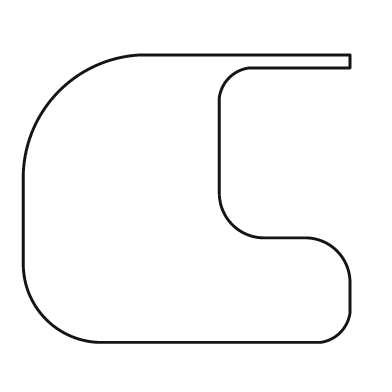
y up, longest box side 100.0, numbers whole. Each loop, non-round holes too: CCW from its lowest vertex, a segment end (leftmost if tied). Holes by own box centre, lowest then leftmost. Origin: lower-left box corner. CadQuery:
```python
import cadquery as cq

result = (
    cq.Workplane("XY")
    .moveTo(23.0, 0.0)
    .lineTo(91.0, 0.0)
    .threePointArc((97.0, 3.0), (100.0, 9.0))
    .lineTo(100.0, 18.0)
    .threePointArc((96.0, 28.0), (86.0, 32.0))
    .lineTo(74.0, 32.0)
    .threePointArc((64.0, 36.0), (60.0, 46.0))
    .lineTo(60.0, 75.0)
    .threePointArc((63.0, 81.0), (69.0, 84.0))
    .lineTo(100.0, 84.0)
    .lineTo(100.0, 88.0)
    .lineTo(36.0, 88.0)
    .threePointArc((11.0, 77.0), (0.0, 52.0))
    .lineTo(0.0, 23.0)
    .threePointArc((7.0, 7.0), (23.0, 0.0))
    .close()
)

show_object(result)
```